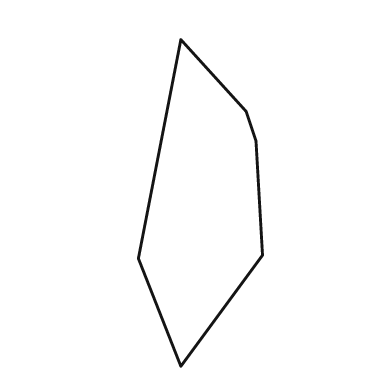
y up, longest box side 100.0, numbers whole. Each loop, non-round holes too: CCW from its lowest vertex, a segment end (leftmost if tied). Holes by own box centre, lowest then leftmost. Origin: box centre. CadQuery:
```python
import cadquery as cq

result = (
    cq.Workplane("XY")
    .moveTo(-6.0, -50.0)
    .lineTo(19.0, -16.0)
    .lineTo(17.0, 19.0)
    .lineTo(14.0, 28.0)
    .lineTo(-6.0, 50.0)
    .lineTo(-19.0, -17.0)
    .close()
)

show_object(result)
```